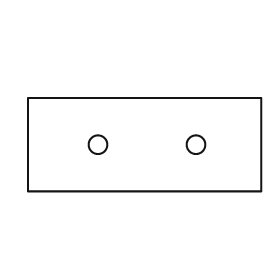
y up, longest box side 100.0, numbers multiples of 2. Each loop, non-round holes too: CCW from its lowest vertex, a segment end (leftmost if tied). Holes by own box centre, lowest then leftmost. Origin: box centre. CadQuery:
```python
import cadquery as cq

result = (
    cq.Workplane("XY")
    .moveTo(-50.0, -20.0)
    .lineTo(50.0, -20.0)
    .lineTo(50.0, 20.0)
    .lineTo(-50.0, 20.0)
    .close()
    .moveTo(-20.0, 0.0)
    .circle(4.0)
    .moveTo(22.0, 0.0)
    .circle(4.0)
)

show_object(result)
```